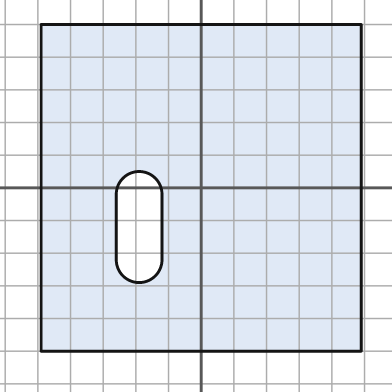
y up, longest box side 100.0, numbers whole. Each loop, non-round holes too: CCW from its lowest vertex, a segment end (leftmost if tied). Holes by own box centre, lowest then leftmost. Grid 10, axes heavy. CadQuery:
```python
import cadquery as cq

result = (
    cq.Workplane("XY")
    .moveTo(-49.0, -50.0)
    .lineTo(49.0, -50.0)
    .lineTo(49.0, 50.0)
    .lineTo(-49.0, 50.0)
    .close()
    .moveTo(-26.0, -22.0)
    .threePointArc((-19.0, -29.0), (-12.0, -22.0))
    .lineTo(-12.0, -2.0)
    .threePointArc((-19.0, 5.0), (-26.0, -2.0))
    .close()
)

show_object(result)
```